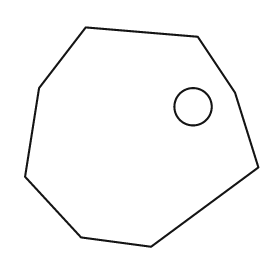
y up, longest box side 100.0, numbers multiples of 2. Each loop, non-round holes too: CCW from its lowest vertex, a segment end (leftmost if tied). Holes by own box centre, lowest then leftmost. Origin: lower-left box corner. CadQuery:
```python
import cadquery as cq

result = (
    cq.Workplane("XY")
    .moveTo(54.0, 0.0)
    .lineTo(100.0, 34.0)
    .lineTo(90.0, 66.0)
    .lineTo(74.0, 90.0)
    .lineTo(26.0, 94.0)
    .lineTo(6.0, 68.0)
    .lineTo(0.0, 30.0)
    .lineTo(24.0, 4.0)
    .close()
    .moveTo(72.0, 60.0)
    .circle(8.0)
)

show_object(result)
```